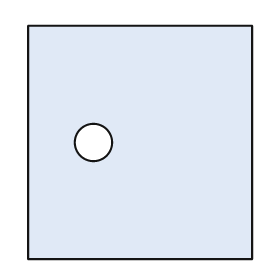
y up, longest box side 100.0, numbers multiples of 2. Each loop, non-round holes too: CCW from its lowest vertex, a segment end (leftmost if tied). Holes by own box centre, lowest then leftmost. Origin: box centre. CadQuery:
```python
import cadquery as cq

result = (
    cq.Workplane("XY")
    .moveTo(-48.0, -50.0)
    .lineTo(48.0, -50.0)
    .lineTo(48.0, 50.0)
    .lineTo(-48.0, 50.0)
    .close()
    .moveTo(-20.0, 0.0)
    .circle(8.0)
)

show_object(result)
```